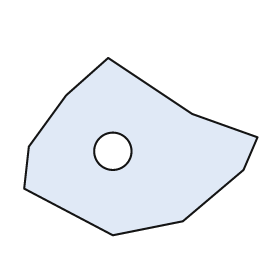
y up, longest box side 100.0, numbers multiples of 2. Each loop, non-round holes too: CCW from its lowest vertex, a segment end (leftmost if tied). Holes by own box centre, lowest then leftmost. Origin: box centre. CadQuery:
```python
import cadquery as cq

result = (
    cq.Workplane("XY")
    .moveTo(-12.0, -38.0)
    .lineTo(18.0, -32.0)
    .lineTo(44.0, -10.0)
    .lineTo(50.0, 4.0)
    .lineTo(22.0, 14.0)
    .lineTo(-14.0, 38.0)
    .lineTo(-32.0, 22.0)
    .lineTo(-48.0, 0.0)
    .lineTo(-50.0, -18.0)
    .close()
    .moveTo(-12.0, -2.0)
    .circle(8.0)
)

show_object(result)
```